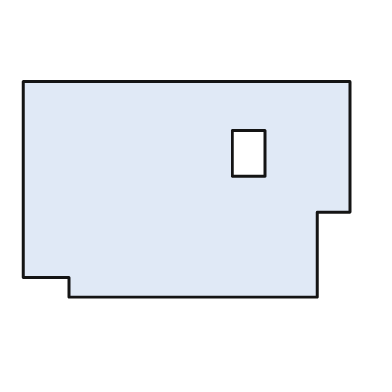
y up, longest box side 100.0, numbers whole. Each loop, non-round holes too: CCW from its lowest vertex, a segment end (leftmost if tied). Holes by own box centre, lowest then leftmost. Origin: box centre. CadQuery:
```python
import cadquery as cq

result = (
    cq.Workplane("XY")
    .moveTo(-36.0, -33.0)
    .lineTo(40.0, -33.0)
    .lineTo(40.0, -7.0)
    .lineTo(50.0, -7.0)
    .lineTo(50.0, 33.0)
    .lineTo(-50.0, 33.0)
    .lineTo(-50.0, -27.0)
    .lineTo(-36.0, -27.0)
    .close()
    .moveTo(14.0, 4.0)
    .lineTo(24.0, 4.0)
    .lineTo(24.0, 18.0)
    .lineTo(14.0, 18.0)
    .close()
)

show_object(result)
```